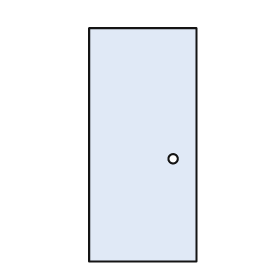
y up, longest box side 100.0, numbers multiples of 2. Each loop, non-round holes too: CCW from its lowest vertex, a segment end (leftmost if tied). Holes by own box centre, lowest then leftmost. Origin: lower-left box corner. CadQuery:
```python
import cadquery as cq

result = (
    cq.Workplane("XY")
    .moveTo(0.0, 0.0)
    .lineTo(46.0, 0.0)
    .lineTo(46.0, 100.0)
    .lineTo(0.0, 100.0)
    .close()
    .moveTo(36.0, 44.0)
    .circle(2.0)
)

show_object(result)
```